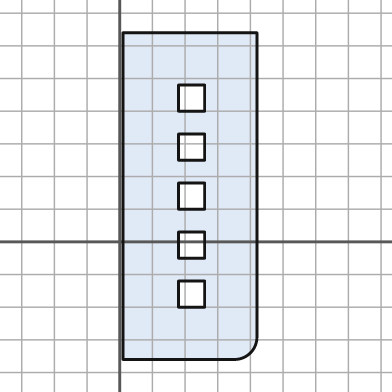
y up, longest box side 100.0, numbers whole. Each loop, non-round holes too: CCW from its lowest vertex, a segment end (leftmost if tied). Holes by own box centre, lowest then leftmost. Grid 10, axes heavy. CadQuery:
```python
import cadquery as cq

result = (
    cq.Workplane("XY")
    .moveTo(1.0, -36.0)
    .lineTo(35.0, -36.0)
    .threePointArc((40.0, -34.0), (42.0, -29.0))
    .lineTo(42.0, 64.0)
    .lineTo(1.0, 64.0)
    .close()
    .moveTo(18.0, -20.0)
    .lineTo(26.0, -20.0)
    .lineTo(26.0, -12.0)
    .lineTo(18.0, -12.0)
    .close()
    .moveTo(18.0, -5.0)
    .lineTo(26.0, -5.0)
    .lineTo(26.0, 3.0)
    .lineTo(18.0, 3.0)
    .close()
    .moveTo(18.0, 10.0)
    .lineTo(26.0, 10.0)
    .lineTo(26.0, 18.0)
    .lineTo(18.0, 18.0)
    .close()
    .moveTo(18.0, 25.0)
    .lineTo(26.0, 25.0)
    .lineTo(26.0, 33.0)
    .lineTo(18.0, 33.0)
    .close()
    .moveTo(18.0, 40.0)
    .lineTo(26.0, 40.0)
    .lineTo(26.0, 48.0)
    .lineTo(18.0, 48.0)
    .close()
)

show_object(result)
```